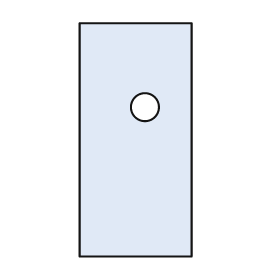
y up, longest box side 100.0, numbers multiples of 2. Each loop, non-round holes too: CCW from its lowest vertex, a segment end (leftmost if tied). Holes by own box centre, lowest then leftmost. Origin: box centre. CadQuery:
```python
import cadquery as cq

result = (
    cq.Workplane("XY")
    .moveTo(-24.0, -50.0)
    .lineTo(24.0, -50.0)
    .lineTo(24.0, 50.0)
    .lineTo(-24.0, 50.0)
    .close()
    .moveTo(4.0, 14.0)
    .circle(6.0)
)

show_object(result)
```